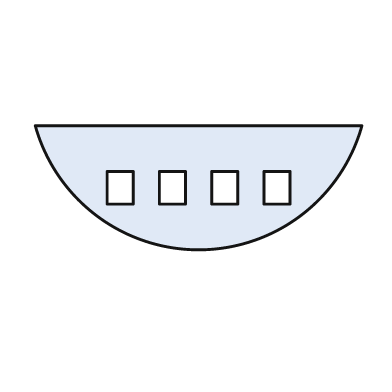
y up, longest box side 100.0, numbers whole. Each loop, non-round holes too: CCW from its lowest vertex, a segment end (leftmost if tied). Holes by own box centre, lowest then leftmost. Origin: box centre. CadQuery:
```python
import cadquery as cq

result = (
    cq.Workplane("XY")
    .moveTo(-50.0, 19.0)
    .threePointArc((0.0, -19.0), (50.0, 19.0))
    .close()
    .moveTo(-28.0, -5.0)
    .lineTo(-20.0, -5.0)
    .lineTo(-20.0, 5.0)
    .lineTo(-28.0, 5.0)
    .close()
    .moveTo(-12.0, -5.0)
    .lineTo(-4.0, -5.0)
    .lineTo(-4.0, 5.0)
    .lineTo(-12.0, 5.0)
    .close()
    .moveTo(4.0, -5.0)
    .lineTo(12.0, -5.0)
    .lineTo(12.0, 5.0)
    .lineTo(4.0, 5.0)
    .close()
    .moveTo(20.0, -5.0)
    .lineTo(28.0, -5.0)
    .lineTo(28.0, 5.0)
    .lineTo(20.0, 5.0)
    .close()
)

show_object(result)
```